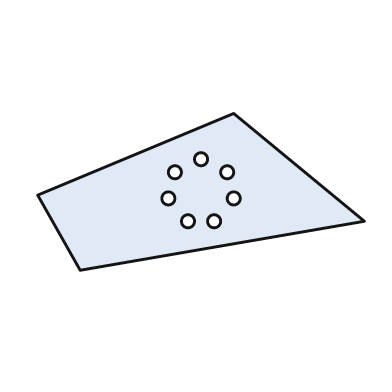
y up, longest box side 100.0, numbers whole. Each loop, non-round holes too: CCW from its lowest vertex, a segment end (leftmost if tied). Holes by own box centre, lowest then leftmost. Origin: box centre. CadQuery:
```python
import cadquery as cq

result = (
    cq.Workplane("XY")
    .moveTo(-37.0, -24.0)
    .lineTo(50.0, -9.0)
    .lineTo(10.0, 24.0)
    .lineTo(-50.0, -1.0)
    .close()
    .moveTo(-4.0, -9.0)
    .circle(2.0)
    .moveTo(4.0, -9.0)
    .circle(2.0)
    .moveTo(-10.0, -2.0)
    .circle(2.0)
    .moveTo(10.0, -2.0)
    .circle(2.0)
    .moveTo(-8.0, 6.0)
    .circle(2.0)
    .moveTo(8.0, 6.0)
    .circle(2.0)
    .moveTo(0.0, 10.0)
    .circle(2.0)
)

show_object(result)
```